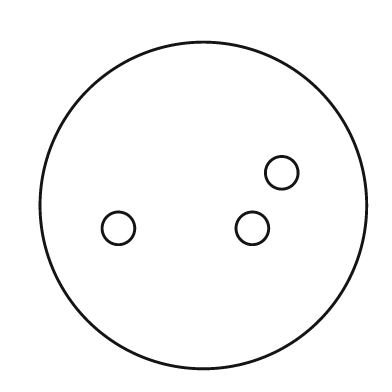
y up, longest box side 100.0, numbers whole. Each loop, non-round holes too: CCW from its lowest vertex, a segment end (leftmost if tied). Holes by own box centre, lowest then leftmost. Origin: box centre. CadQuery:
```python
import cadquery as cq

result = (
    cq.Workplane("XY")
    .moveTo(0.0, 0.0)
    .circle(50.0)
    .moveTo(-26.0, -7.0)
    .circle(5.0)
    .moveTo(15.0, -7.0)
    .circle(5.0)
    .moveTo(24.0, 10.0)
    .circle(5.0)
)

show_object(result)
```